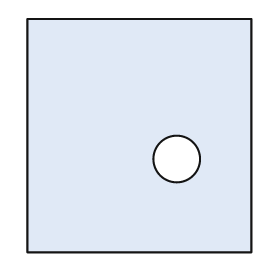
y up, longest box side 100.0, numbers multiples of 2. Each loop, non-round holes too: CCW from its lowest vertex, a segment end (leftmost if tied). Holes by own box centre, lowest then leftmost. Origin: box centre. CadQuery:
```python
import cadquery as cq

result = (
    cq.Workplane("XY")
    .moveTo(-48.0, -50.0)
    .lineTo(48.0, -50.0)
    .lineTo(48.0, 50.0)
    .lineTo(-48.0, 50.0)
    .close()
    .moveTo(16.0, -10.0)
    .circle(10.0)
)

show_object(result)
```